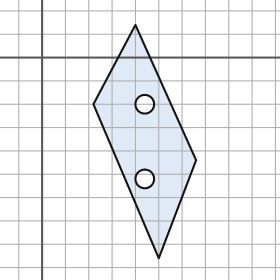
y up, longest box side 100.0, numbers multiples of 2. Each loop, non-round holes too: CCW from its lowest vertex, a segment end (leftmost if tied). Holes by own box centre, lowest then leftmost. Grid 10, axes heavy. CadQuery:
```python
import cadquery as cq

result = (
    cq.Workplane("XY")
    .moveTo(50.0, -86.0)
    .lineTo(66.0, -44.0)
    .lineTo(40.0, 14.0)
    .lineTo(22.0, -20.0)
    .close()
    .moveTo(44.0, -52.0)
    .circle(4.0)
    .moveTo(44.0, -20.0)
    .circle(4.0)
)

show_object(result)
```